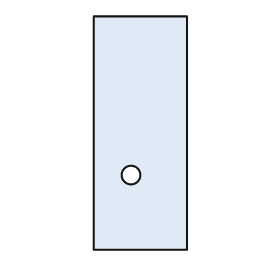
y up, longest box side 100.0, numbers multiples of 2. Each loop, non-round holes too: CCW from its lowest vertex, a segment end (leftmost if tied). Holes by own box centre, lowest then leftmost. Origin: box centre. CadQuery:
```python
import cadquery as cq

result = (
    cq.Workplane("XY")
    .moveTo(-20.0, -50.0)
    .lineTo(20.0, -50.0)
    .lineTo(20.0, 50.0)
    .lineTo(-20.0, 50.0)
    .close()
    .moveTo(-4.0, -18.0)
    .circle(4.0)
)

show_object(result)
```